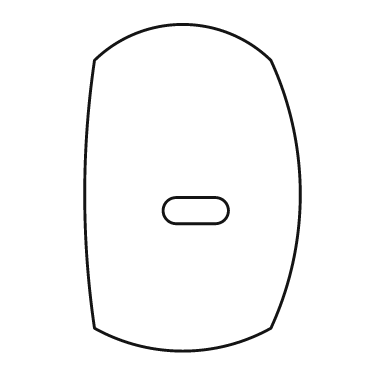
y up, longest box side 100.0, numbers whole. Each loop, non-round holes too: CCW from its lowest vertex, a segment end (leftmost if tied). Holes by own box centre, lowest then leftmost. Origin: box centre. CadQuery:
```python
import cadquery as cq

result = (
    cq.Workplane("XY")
    .moveTo(-30.0, -43.0)
    .threePointArc((-3.0, -50.0), (24.0, -43.0))
    .threePointArc((33.0, -2.0), (24.0, 39.0))
    .threePointArc((-3.0, 50.0), (-30.0, 39.0))
    .threePointArc((-33.0, -2.0), (-30.0, -43.0))
    .close()
    .moveTo(-5.0, -11.0)
    .lineTo(7.0, -11.0)
    .threePointArc((11.0, -7.0), (7.0, -3.0))
    .lineTo(-5.0, -3.0)
    .threePointArc((-9.0, -7.0), (-5.0, -11.0))
    .close()
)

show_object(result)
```